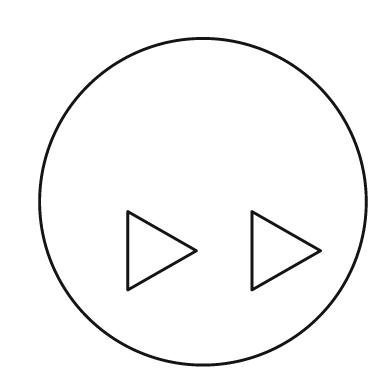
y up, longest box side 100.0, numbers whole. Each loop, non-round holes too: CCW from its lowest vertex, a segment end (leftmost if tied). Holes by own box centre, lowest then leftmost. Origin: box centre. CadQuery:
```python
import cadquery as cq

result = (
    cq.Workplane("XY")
    .moveTo(0.0, 0.0)
    .circle(50.0)
    .moveTo(-23.0, -27.0)
    .lineTo(-2.0, -15.0)
    .lineTo(-23.0, -3.0)
    .close()
    .moveTo(15.0, -27.0)
    .lineTo(36.0, -15.0)
    .lineTo(15.0, -3.0)
    .close()
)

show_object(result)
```